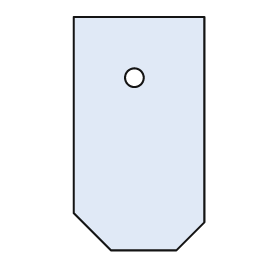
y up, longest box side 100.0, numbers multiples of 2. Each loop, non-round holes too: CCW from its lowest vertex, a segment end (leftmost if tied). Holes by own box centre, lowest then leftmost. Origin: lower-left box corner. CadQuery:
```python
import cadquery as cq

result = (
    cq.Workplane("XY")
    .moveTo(16.0, 0.0)
    .lineTo(44.0, 0.0)
    .lineTo(56.0, 12.0)
    .lineTo(56.0, 100.0)
    .lineTo(0.0, 100.0)
    .lineTo(0.0, 16.0)
    .close()
    .moveTo(26.0, 74.0)
    .circle(4.0)
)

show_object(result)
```